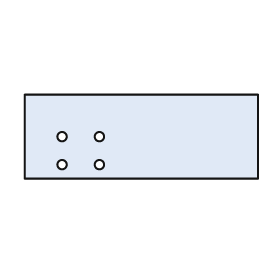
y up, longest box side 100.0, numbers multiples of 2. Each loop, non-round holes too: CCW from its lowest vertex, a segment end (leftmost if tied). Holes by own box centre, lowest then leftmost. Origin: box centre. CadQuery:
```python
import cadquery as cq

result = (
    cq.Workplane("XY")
    .moveTo(-50.0, -18.0)
    .lineTo(50.0, -18.0)
    .lineTo(50.0, 18.0)
    .lineTo(-50.0, 18.0)
    .close()
    .moveTo(-34.0, -12.0)
    .circle(2.0)
    .moveTo(-18.0, -12.0)
    .circle(2.0)
    .moveTo(-34.0, 0.0)
    .circle(2.0)
    .moveTo(-18.0, 0.0)
    .circle(2.0)
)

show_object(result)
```